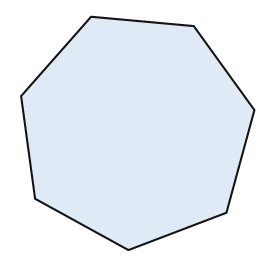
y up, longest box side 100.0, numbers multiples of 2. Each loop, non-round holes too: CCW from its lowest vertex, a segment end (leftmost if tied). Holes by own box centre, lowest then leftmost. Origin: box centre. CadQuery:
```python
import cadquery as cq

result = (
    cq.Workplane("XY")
    .moveTo(-4.0, -50.0)
    .lineTo(38.0, -34.0)
    .lineTo(50.0, 10.0)
    .lineTo(24.0, 46.0)
    .lineTo(-20.0, 50.0)
    .lineTo(-50.0, 16.0)
    .lineTo(-44.0, -28.0)
    .close()
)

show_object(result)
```